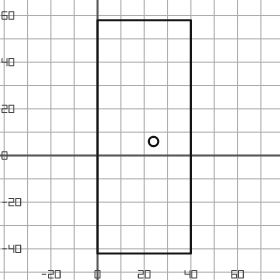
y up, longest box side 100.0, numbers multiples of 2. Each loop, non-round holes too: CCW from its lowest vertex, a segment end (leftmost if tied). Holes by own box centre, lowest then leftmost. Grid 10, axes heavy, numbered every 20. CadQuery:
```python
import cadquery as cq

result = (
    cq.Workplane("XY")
    .moveTo(0.0, -42.0)
    .lineTo(40.0, -42.0)
    .lineTo(40.0, 58.0)
    .lineTo(0.0, 58.0)
    .close()
    .moveTo(24.0, 6.0)
    .circle(2.0)
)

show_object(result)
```